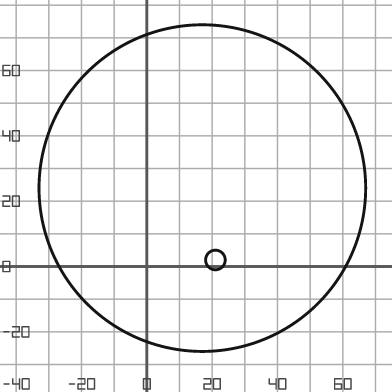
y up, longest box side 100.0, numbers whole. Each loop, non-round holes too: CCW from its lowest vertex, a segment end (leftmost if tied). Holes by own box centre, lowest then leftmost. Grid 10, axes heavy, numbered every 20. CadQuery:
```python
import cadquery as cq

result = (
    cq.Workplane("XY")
    .moveTo(17.0, 24.0)
    .circle(50.0)
    .moveTo(21.0, 2.0)
    .circle(3.0)
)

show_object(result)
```